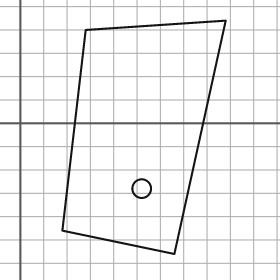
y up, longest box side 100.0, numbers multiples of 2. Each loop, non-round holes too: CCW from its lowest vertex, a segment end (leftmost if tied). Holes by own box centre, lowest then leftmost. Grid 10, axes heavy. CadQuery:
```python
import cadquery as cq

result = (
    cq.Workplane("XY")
    .moveTo(66.0, -56.0)
    .lineTo(88.0, 44.0)
    .lineTo(28.0, 40.0)
    .lineTo(18.0, -46.0)
    .close()
    .moveTo(52.0, -28.0)
    .circle(4.0)
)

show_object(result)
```